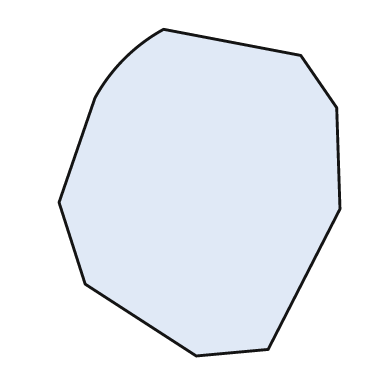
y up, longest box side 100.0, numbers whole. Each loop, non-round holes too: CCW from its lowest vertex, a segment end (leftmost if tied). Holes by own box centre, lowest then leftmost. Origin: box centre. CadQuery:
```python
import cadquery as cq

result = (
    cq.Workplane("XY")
    .moveTo(-1.0, -50.0)
    .lineTo(21.0, -48.0)
    .lineTo(43.0, -5.0)
    .lineTo(42.0, 26.0)
    .lineTo(31.0, 42.0)
    .lineTo(-11.0, 50.0)
    .threePointArc((-23.0, 41.0), (-32.0, 29.0))
    .lineTo(-43.0, -3.0)
    .lineTo(-35.0, -28.0)
    .close()
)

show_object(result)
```